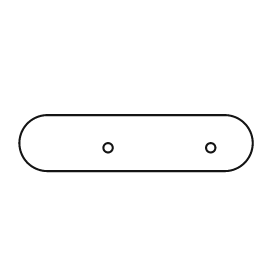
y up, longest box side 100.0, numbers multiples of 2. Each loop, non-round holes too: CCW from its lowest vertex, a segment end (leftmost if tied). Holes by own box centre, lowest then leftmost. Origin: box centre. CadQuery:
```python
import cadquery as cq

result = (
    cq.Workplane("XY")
    .moveTo(-38.0, -12.0)
    .lineTo(38.0, -12.0)
    .threePointArc((50.0, 0.0), (38.0, 12.0))
    .lineTo(-38.0, 12.0)
    .threePointArc((-50.0, 0.0), (-38.0, -12.0))
    .close()
    .moveTo(-12.0, -2.0)
    .circle(2.0)
    .moveTo(32.0, -2.0)
    .circle(2.0)
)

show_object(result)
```